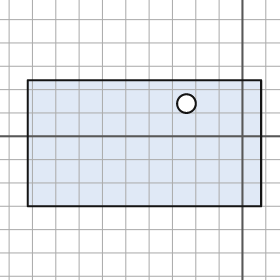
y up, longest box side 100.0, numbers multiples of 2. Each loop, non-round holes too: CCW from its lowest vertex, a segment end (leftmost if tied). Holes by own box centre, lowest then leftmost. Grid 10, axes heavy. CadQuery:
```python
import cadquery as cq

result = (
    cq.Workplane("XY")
    .moveTo(-92.0, -30.0)
    .lineTo(8.0, -30.0)
    .lineTo(8.0, 24.0)
    .lineTo(-92.0, 24.0)
    .close()
    .moveTo(-24.0, 14.0)
    .circle(4.0)
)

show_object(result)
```